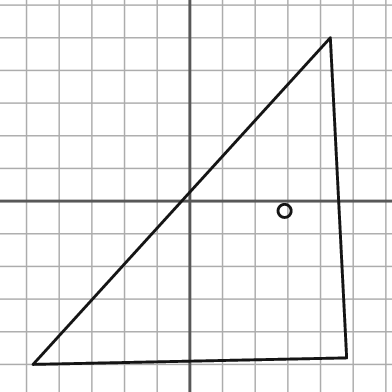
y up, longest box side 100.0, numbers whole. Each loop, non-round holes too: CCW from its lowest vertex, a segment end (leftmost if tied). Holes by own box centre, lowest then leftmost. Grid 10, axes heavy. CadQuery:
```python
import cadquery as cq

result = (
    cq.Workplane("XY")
    .moveTo(-48.0, -50.0)
    .lineTo(48.0, -48.0)
    .lineTo(43.0, 50.0)
    .close()
    .moveTo(29.0, -3.0)
    .circle(2.0)
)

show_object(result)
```